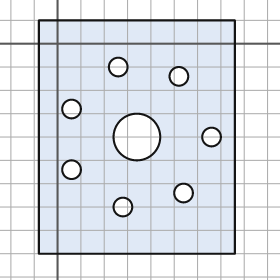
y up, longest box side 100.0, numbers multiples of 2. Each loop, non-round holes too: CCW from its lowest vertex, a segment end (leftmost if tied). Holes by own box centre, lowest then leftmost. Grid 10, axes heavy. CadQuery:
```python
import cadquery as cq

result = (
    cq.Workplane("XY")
    .moveTo(-8.0, -90.0)
    .lineTo(76.0, -90.0)
    .lineTo(76.0, 10.0)
    .lineTo(-8.0, 10.0)
    .close()
    .moveTo(28.0, -70.0)
    .circle(4.0)
    .moveTo(54.0, -64.0)
    .circle(4.0)
    .moveTo(6.0, -54.0)
    .circle(4.0)
    .moveTo(34.0, -40.0)
    .circle(10.0)
    .moveTo(66.0, -40.0)
    .circle(4.0)
    .moveTo(6.0, -28.0)
    .circle(4.0)
    .moveTo(52.0, -14.0)
    .circle(4.0)
    .moveTo(26.0, -10.0)
    .circle(4.0)
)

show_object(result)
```